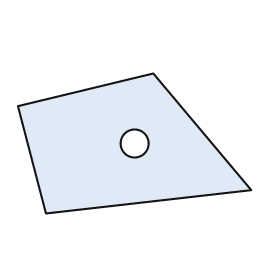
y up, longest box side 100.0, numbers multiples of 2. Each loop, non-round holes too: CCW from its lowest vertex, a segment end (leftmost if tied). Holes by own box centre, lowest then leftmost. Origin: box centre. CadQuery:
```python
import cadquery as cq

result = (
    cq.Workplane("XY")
    .moveTo(-38.0, -30.0)
    .lineTo(50.0, -20.0)
    .lineTo(8.0, 30.0)
    .lineTo(-50.0, 16.0)
    .close()
    .moveTo(0.0, 0.0)
    .circle(6.0)
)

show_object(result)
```